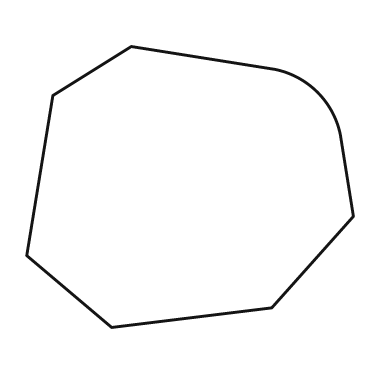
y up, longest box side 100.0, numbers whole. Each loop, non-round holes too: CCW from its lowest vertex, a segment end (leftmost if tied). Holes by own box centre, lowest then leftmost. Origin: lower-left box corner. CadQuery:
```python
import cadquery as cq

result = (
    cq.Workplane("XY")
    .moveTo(26.0, 0.0)
    .lineTo(75.0, 6.0)
    .lineTo(100.0, 34.0)
    .lineTo(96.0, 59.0)
    .threePointArc((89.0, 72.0), (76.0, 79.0))
    .lineTo(32.0, 86.0)
    .lineTo(8.0, 71.0)
    .lineTo(0.0, 22.0)
    .close()
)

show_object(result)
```